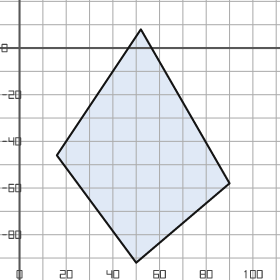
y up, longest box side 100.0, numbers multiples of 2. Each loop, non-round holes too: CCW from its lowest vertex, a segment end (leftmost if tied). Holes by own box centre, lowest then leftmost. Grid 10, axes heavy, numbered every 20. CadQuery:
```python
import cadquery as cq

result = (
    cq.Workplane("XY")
    .moveTo(50.0, -92.0)
    .lineTo(90.0, -58.0)
    .lineTo(52.0, 8.0)
    .lineTo(16.0, -46.0)
    .close()
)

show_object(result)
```